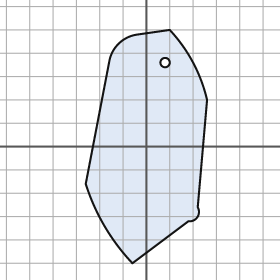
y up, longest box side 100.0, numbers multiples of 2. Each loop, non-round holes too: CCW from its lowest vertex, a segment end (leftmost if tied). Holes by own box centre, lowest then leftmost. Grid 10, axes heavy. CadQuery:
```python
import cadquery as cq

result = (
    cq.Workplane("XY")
    .moveTo(-6.0, -50.0)
    .lineTo(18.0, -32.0)
    .threePointArc((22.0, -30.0), (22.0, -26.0))
    .lineTo(26.0, 20.0)
    .threePointArc((20.0, 36.0), (10.0, 50.0))
    .lineTo(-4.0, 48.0)
    .threePointArc((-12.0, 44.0), (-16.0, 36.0))
    .lineTo(-26.0, -16.0)
    .threePointArc((-18.0, -34.0), (-6.0, -50.0))
    .close()
    .moveTo(8.0, 36.0)
    .circle(2.0)
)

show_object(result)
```